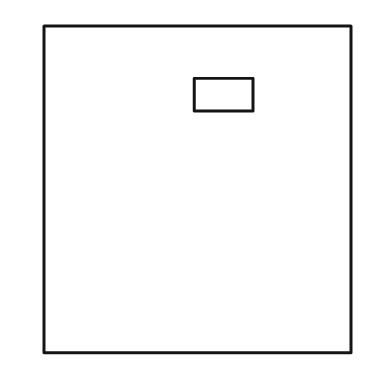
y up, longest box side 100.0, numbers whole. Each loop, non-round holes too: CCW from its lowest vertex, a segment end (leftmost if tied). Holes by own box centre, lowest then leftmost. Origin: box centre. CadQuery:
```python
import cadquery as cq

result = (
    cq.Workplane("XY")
    .moveTo(-47.0, -50.0)
    .lineTo(47.0, -50.0)
    .lineTo(47.0, 50.0)
    .lineTo(-47.0, 50.0)
    .close()
    .moveTo(-1.0, 24.0)
    .lineTo(17.0, 24.0)
    .lineTo(17.0, 34.0)
    .lineTo(-1.0, 34.0)
    .close()
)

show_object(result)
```